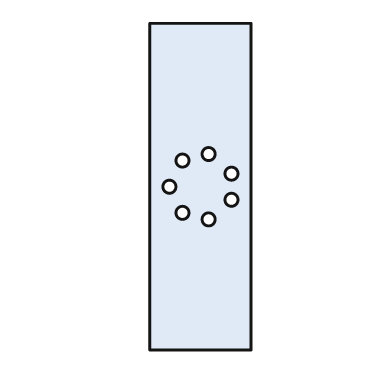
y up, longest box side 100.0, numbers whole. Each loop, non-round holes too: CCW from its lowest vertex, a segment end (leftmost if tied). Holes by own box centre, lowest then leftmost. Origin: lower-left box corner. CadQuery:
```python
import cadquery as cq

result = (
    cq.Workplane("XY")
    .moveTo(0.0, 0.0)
    .lineTo(31.0, 0.0)
    .lineTo(31.0, 100.0)
    .lineTo(0.0, 100.0)
    .close()
    .moveTo(18.0, 40.0)
    .circle(2.0)
    .moveTo(10.0, 42.0)
    .circle(2.0)
    .moveTo(25.0, 46.0)
    .circle(2.0)
    .moveTo(6.0, 50.0)
    .circle(2.0)
    .moveTo(25.0, 54.0)
    .circle(2.0)
    .moveTo(10.0, 58.0)
    .circle(2.0)
    .moveTo(18.0, 60.0)
    .circle(2.0)
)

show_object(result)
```